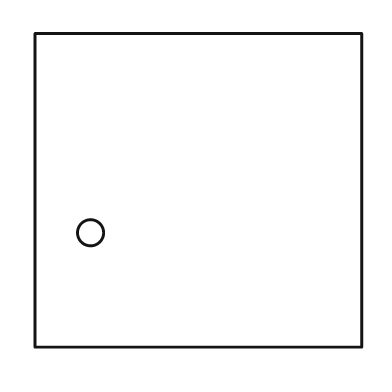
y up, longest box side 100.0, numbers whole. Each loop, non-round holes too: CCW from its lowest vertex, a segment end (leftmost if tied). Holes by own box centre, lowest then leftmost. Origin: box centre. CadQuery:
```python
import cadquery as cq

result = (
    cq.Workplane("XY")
    .moveTo(-50.0, -48.0)
    .lineTo(50.0, -48.0)
    .lineTo(50.0, 48.0)
    .lineTo(-50.0, 48.0)
    .close()
    .moveTo(-33.0, -13.0)
    .circle(4.0)
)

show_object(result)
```